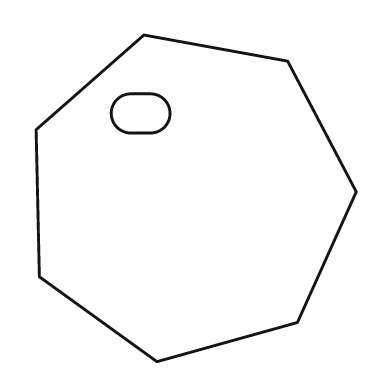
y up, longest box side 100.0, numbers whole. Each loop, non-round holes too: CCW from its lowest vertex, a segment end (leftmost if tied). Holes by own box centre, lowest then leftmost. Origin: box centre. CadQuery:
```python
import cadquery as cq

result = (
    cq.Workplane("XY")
    .moveTo(-12.0, -50.0)
    .lineTo(31.0, -38.0)
    .lineTo(49.0, 2.0)
    .lineTo(28.0, 42.0)
    .lineTo(-16.0, 50.0)
    .lineTo(-49.0, 21.0)
    .lineTo(-48.0, -24.0)
    .close()
    .moveTo(-20.0, 20.0)
    .lineTo(-14.0, 20.0)
    .threePointArc((-8.0, 26.0), (-14.0, 32.0))
    .lineTo(-20.0, 32.0)
    .threePointArc((-26.0, 26.0), (-20.0, 20.0))
    .close()
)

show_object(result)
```